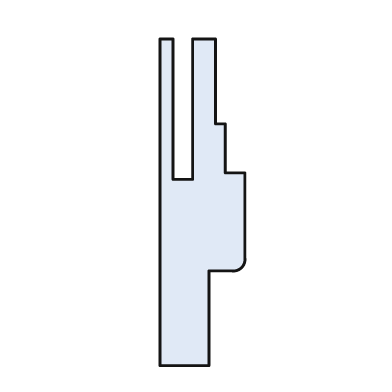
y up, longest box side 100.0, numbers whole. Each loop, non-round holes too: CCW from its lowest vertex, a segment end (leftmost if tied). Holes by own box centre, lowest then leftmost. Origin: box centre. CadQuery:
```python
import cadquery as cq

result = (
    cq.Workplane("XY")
    .moveTo(-13.0, -50.0)
    .lineTo(2.0, -50.0)
    .lineTo(2.0, -21.0)
    .lineTo(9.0, -21.0)
    .threePointArc((12.0, -20.0), (13.0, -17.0))
    .lineTo(13.0, 9.0)
    .lineTo(7.0, 9.0)
    .lineTo(7.0, 24.0)
    .lineTo(4.0, 24.0)
    .lineTo(4.0, 50.0)
    .lineTo(-3.0, 50.0)
    .lineTo(-3.0, 7.0)
    .lineTo(-9.0, 7.0)
    .lineTo(-9.0, 50.0)
    .lineTo(-13.0, 50.0)
    .close()
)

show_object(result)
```